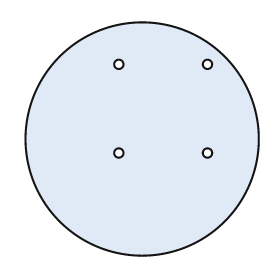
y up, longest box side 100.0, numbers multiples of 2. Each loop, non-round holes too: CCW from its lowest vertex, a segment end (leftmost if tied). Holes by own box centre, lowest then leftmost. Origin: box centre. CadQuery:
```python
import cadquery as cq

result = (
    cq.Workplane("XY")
    .moveTo(0.0, 0.0)
    .circle(50.0)
    .moveTo(-10.0, -6.0)
    .circle(2.0)
    .moveTo(28.0, -6.0)
    .circle(2.0)
    .moveTo(-10.0, 32.0)
    .circle(2.0)
    .moveTo(28.0, 32.0)
    .circle(2.0)
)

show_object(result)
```